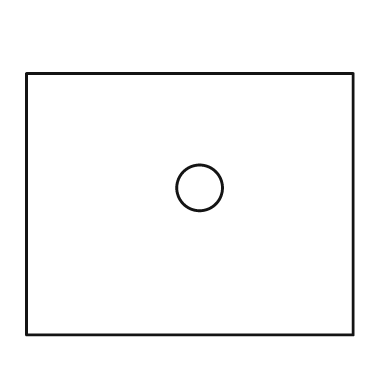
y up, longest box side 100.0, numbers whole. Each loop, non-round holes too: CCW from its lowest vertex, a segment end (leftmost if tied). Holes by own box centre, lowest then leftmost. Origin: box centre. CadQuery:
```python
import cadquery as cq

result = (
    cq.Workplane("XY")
    .moveTo(-50.0, -40.0)
    .lineTo(50.0, -40.0)
    .lineTo(50.0, 40.0)
    .lineTo(-50.0, 40.0)
    .close()
    .moveTo(3.0, 5.0)
    .circle(7.0)
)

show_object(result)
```